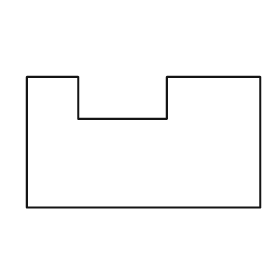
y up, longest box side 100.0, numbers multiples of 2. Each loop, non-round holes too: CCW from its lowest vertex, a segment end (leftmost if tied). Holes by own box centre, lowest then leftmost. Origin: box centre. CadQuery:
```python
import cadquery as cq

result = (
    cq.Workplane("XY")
    .moveTo(-50.0, -28.0)
    .lineTo(50.0, -28.0)
    .lineTo(50.0, 28.0)
    .lineTo(10.0, 28.0)
    .lineTo(10.0, 10.0)
    .lineTo(-28.0, 10.0)
    .lineTo(-28.0, 28.0)
    .lineTo(-50.0, 28.0)
    .close()
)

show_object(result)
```